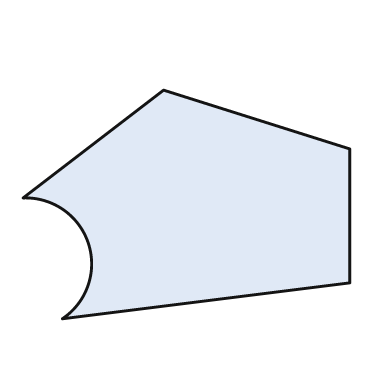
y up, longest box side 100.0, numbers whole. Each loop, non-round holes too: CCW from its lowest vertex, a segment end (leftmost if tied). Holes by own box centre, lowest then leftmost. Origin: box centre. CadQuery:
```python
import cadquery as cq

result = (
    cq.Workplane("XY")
    .moveTo(-38.0, -35.0)
    .lineTo(50.0, -24.0)
    .lineTo(50.0, 17.0)
    .lineTo(-7.0, 35.0)
    .lineTo(-50.0, 2.0)
    .threePointArc((-30.0, -12.0), (-38.0, -35.0))
    .close()
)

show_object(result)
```